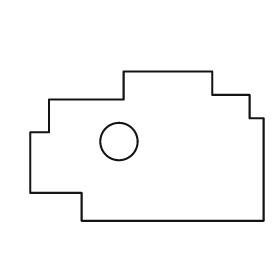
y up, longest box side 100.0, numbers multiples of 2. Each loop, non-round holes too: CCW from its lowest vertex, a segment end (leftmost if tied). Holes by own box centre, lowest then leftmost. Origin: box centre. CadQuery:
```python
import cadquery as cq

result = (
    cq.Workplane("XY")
    .moveTo(-28.0, -32.0)
    .lineTo(50.0, -32.0)
    .lineTo(50.0, 12.0)
    .lineTo(44.0, 12.0)
    .lineTo(44.0, 22.0)
    .lineTo(28.0, 22.0)
    .lineTo(28.0, 32.0)
    .lineTo(-10.0, 32.0)
    .lineTo(-10.0, 20.0)
    .lineTo(-42.0, 20.0)
    .lineTo(-42.0, 6.0)
    .lineTo(-50.0, 6.0)
    .lineTo(-50.0, -20.0)
    .lineTo(-28.0, -20.0)
    .close()
    .moveTo(-12.0, 2.0)
    .circle(8.0)
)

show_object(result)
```